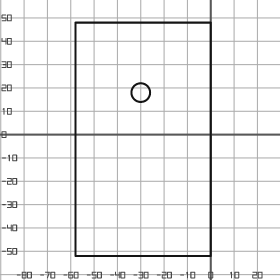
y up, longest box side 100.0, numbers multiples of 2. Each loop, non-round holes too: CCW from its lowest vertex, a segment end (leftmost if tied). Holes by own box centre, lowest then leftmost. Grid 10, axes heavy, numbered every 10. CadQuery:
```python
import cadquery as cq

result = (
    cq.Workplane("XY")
    .moveTo(-58.0, -52.0)
    .lineTo(0.0, -52.0)
    .lineTo(0.0, 48.0)
    .lineTo(-58.0, 48.0)
    .close()
    .moveTo(-30.0, 18.0)
    .circle(4.0)
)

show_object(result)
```